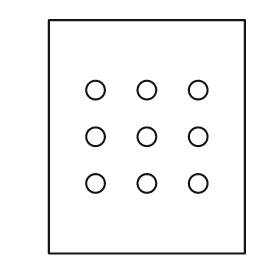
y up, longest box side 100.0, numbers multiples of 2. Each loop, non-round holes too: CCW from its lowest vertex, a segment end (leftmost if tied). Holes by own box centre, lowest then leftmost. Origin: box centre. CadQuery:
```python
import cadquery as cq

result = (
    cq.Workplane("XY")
    .moveTo(-42.0, -50.0)
    .lineTo(42.0, -50.0)
    .lineTo(42.0, 50.0)
    .lineTo(-42.0, 50.0)
    .close()
    .moveTo(-22.0, -20.0)
    .circle(4.0)
    .moveTo(0.0, -20.0)
    .circle(4.0)
    .moveTo(22.0, -20.0)
    .circle(4.0)
    .moveTo(-22.0, 0.0)
    .circle(4.0)
    .moveTo(0.0, 0.0)
    .circle(4.0)
    .moveTo(22.0, 0.0)
    .circle(4.0)
    .moveTo(-22.0, 20.0)
    .circle(4.0)
    .moveTo(0.0, 20.0)
    .circle(4.0)
    .moveTo(22.0, 20.0)
    .circle(4.0)
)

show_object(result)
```